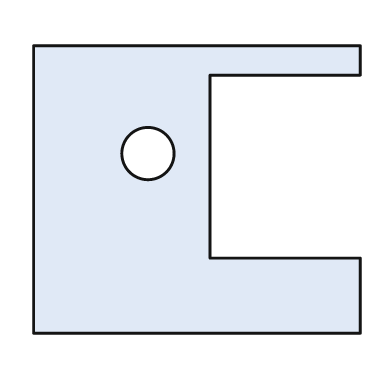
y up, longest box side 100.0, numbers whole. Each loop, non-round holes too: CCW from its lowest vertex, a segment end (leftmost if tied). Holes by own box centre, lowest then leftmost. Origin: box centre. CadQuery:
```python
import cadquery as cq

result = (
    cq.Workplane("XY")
    .moveTo(-50.0, -44.0)
    .lineTo(50.0, -44.0)
    .lineTo(50.0, -21.0)
    .lineTo(4.0, -21.0)
    .lineTo(4.0, 35.0)
    .lineTo(50.0, 35.0)
    .lineTo(50.0, 44.0)
    .lineTo(-50.0, 44.0)
    .close()
    .moveTo(-15.0, 11.0)
    .circle(8.0)
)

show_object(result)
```